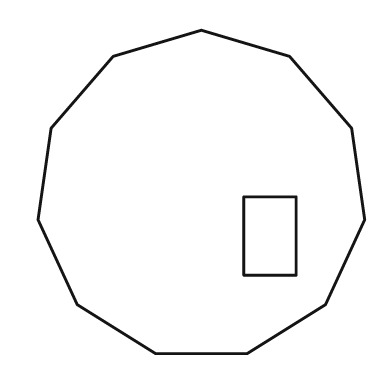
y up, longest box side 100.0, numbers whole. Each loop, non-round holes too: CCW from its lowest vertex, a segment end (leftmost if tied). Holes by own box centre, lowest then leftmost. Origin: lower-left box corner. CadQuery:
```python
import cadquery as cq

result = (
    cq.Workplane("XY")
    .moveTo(36.0, 0.0)
    .lineTo(64.0, 0.0)
    .lineTo(88.0, 15.0)
    .lineTo(100.0, 41.0)
    .lineTo(96.0, 69.0)
    .lineTo(77.0, 91.0)
    .lineTo(50.0, 99.0)
    .lineTo(23.0, 91.0)
    .lineTo(4.0, 69.0)
    .lineTo(0.0, 41.0)
    .lineTo(12.0, 15.0)
    .close()
    .moveTo(63.0, 24.0)
    .lineTo(79.0, 24.0)
    .lineTo(79.0, 48.0)
    .lineTo(63.0, 48.0)
    .close()
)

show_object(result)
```